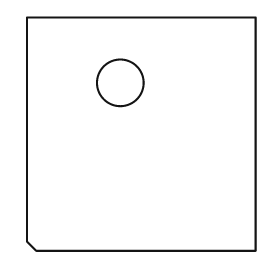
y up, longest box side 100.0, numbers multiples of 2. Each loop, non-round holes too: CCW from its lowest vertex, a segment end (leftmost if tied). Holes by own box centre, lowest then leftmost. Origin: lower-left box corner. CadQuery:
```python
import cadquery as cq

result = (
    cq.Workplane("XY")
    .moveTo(4.0, 0.0)
    .lineTo(98.0, 0.0)
    .lineTo(98.0, 100.0)
    .lineTo(0.0, 100.0)
    .lineTo(0.0, 4.0)
    .close()
    .moveTo(40.0, 72.0)
    .circle(10.0)
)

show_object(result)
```